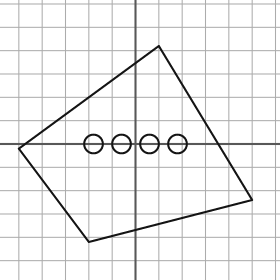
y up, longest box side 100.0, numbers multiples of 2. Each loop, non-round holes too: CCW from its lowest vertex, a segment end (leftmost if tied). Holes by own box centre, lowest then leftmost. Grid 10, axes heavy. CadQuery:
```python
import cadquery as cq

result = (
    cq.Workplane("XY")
    .moveTo(-20.0, -42.0)
    .lineTo(50.0, -24.0)
    .lineTo(10.0, 42.0)
    .lineTo(-50.0, -2.0)
    .close()
    .moveTo(-18.0, 0.0)
    .circle(4.0)
    .moveTo(-6.0, 0.0)
    .circle(4.0)
    .moveTo(6.0, 0.0)
    .circle(4.0)
    .moveTo(18.0, 0.0)
    .circle(4.0)
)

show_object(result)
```